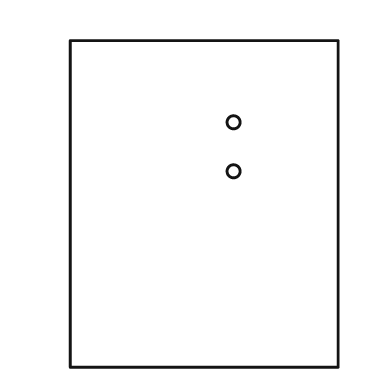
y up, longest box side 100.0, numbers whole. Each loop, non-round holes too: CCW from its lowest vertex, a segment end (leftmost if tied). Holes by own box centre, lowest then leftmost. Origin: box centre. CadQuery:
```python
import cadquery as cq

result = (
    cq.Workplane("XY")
    .moveTo(-41.0, -50.0)
    .lineTo(41.0, -50.0)
    .lineTo(41.0, 50.0)
    .lineTo(-41.0, 50.0)
    .close()
    .moveTo(9.0, 10.0)
    .circle(2.0)
    .moveTo(9.0, 25.0)
    .circle(2.0)
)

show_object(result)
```